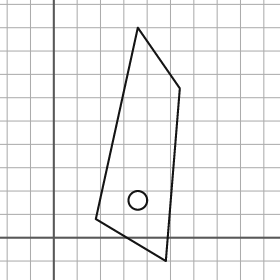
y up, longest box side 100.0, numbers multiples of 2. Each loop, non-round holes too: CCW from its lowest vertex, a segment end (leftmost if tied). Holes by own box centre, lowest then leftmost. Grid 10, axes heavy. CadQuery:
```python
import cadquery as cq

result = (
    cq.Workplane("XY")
    .moveTo(48.0, -10.0)
    .lineTo(54.0, 64.0)
    .lineTo(36.0, 90.0)
    .lineTo(18.0, 8.0)
    .close()
    .moveTo(36.0, 16.0)
    .circle(4.0)
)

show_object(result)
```